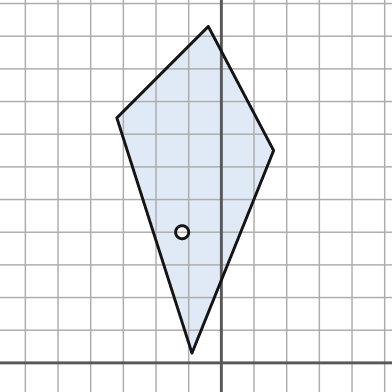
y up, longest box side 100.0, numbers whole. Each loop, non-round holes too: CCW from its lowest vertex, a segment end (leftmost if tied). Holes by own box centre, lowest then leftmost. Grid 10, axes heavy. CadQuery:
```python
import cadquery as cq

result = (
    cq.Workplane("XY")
    .moveTo(-9.0, 3.0)
    .lineTo(16.0, 65.0)
    .lineTo(-4.0, 103.0)
    .lineTo(-32.0, 75.0)
    .close()
    .moveTo(-12.0, 40.0)
    .circle(2.0)
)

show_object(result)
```